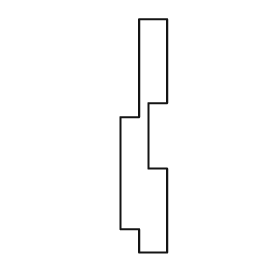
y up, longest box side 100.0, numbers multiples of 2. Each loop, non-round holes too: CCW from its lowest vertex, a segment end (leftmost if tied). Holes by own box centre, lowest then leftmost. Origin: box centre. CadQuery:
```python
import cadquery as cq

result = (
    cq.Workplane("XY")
    .moveTo(-2.0, -50.0)
    .lineTo(10.0, -50.0)
    .lineTo(10.0, -14.0)
    .lineTo(2.0, -14.0)
    .lineTo(2.0, 14.0)
    .lineTo(10.0, 14.0)
    .lineTo(10.0, 50.0)
    .lineTo(-2.0, 50.0)
    .lineTo(-2.0, 8.0)
    .lineTo(-10.0, 8.0)
    .lineTo(-10.0, -40.0)
    .lineTo(-2.0, -40.0)
    .close()
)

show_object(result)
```